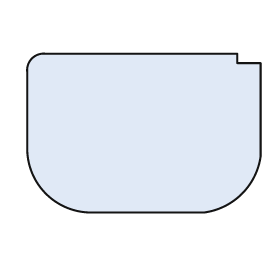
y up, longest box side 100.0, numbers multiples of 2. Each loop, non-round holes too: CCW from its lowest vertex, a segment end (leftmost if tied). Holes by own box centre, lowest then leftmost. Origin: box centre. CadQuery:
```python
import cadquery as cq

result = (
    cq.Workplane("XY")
    .moveTo(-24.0, -34.0)
    .lineTo(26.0, -34.0)
    .threePointArc((42.0, -26.0), (50.0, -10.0))
    .lineTo(50.0, 30.0)
    .lineTo(40.0, 30.0)
    .lineTo(40.0, 34.0)
    .lineTo(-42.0, 34.0)
    .threePointArc((-48.0, 32.0), (-50.0, 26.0))
    .lineTo(-50.0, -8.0)
    .threePointArc((-42.0, -26.0), (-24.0, -34.0))
    .close()
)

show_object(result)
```